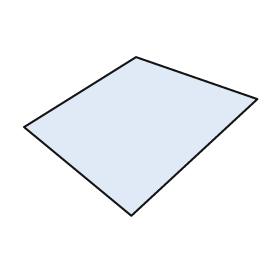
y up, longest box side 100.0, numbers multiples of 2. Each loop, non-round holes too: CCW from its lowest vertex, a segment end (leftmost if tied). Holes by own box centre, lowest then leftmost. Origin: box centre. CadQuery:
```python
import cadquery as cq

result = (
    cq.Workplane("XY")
    .moveTo(-4.0, -34.0)
    .lineTo(50.0, 16.0)
    .lineTo(-2.0, 34.0)
    .lineTo(-50.0, 4.0)
    .close()
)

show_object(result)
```